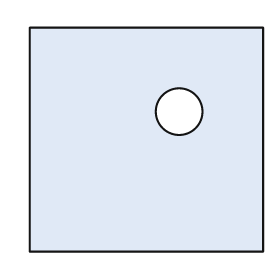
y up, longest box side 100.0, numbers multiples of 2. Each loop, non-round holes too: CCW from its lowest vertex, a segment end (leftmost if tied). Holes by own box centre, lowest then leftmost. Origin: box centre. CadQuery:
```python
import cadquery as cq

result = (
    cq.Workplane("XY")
    .moveTo(-50.0, -48.0)
    .lineTo(50.0, -48.0)
    .lineTo(50.0, 48.0)
    .lineTo(-50.0, 48.0)
    .close()
    .moveTo(14.0, 12.0)
    .circle(10.0)
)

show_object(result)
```